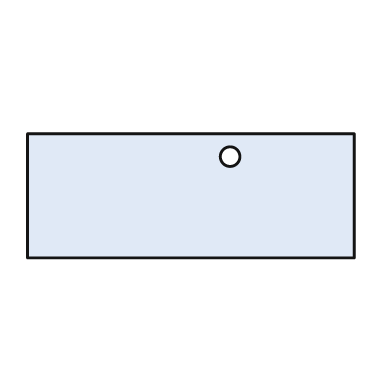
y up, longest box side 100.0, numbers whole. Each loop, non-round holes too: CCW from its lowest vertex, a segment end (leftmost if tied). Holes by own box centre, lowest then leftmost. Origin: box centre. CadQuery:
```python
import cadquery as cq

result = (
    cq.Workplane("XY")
    .moveTo(-50.0, -19.0)
    .lineTo(50.0, -19.0)
    .lineTo(50.0, 19.0)
    .lineTo(-50.0, 19.0)
    .close()
    .moveTo(12.0, 12.0)
    .circle(3.0)
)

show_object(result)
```